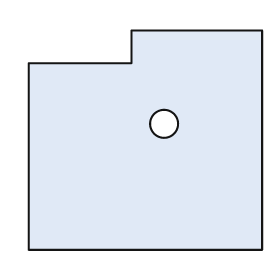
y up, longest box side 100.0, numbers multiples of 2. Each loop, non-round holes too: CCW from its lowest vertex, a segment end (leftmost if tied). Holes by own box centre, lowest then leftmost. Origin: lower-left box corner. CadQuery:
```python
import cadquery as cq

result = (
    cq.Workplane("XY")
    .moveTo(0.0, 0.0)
    .lineTo(100.0, 0.0)
    .lineTo(100.0, 94.0)
    .lineTo(44.0, 94.0)
    .lineTo(44.0, 80.0)
    .lineTo(0.0, 80.0)
    .close()
    .moveTo(58.0, 54.0)
    .circle(6.0)
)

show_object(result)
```